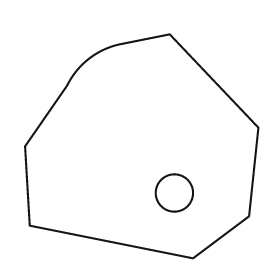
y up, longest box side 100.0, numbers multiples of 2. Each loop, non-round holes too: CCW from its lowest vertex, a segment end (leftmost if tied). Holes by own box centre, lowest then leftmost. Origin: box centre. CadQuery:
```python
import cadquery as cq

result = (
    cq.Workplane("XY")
    .moveTo(22.0, -48.0)
    .lineTo(46.0, -30.0)
    .lineTo(50.0, 8.0)
    .lineTo(12.0, 48.0)
    .lineTo(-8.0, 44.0)
    .threePointArc((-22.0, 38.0), (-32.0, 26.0))
    .lineTo(-50.0, 0.0)
    .lineTo(-48.0, -34.0)
    .close()
    .moveTo(14.0, -20.0)
    .circle(8.0)
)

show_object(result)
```